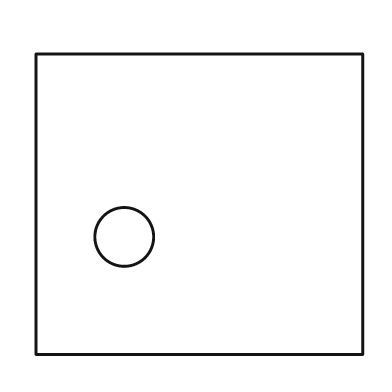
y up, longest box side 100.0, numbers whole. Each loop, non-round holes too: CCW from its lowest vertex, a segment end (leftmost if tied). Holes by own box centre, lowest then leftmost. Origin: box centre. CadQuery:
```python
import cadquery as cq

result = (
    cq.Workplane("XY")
    .moveTo(-50.0, -46.0)
    .lineTo(50.0, -46.0)
    .lineTo(50.0, 46.0)
    .lineTo(-50.0, 46.0)
    .close()
    .moveTo(-23.0, -10.0)
    .circle(9.0)
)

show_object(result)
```